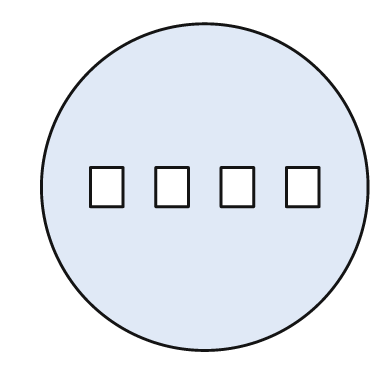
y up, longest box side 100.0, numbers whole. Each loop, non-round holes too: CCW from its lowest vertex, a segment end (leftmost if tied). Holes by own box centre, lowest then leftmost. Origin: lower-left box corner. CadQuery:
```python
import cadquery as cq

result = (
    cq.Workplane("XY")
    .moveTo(50.0, 50.0)
    .circle(50.0)
    .moveTo(15.0, 44.0)
    .lineTo(25.0, 44.0)
    .lineTo(25.0, 56.0)
    .lineTo(15.0, 56.0)
    .close()
    .moveTo(35.0, 44.0)
    .lineTo(45.0, 44.0)
    .lineTo(45.0, 56.0)
    .lineTo(35.0, 56.0)
    .close()
    .moveTo(55.0, 44.0)
    .lineTo(65.0, 44.0)
    .lineTo(65.0, 56.0)
    .lineTo(55.0, 56.0)
    .close()
    .moveTo(75.0, 44.0)
    .lineTo(85.0, 44.0)
    .lineTo(85.0, 56.0)
    .lineTo(75.0, 56.0)
    .close()
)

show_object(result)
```